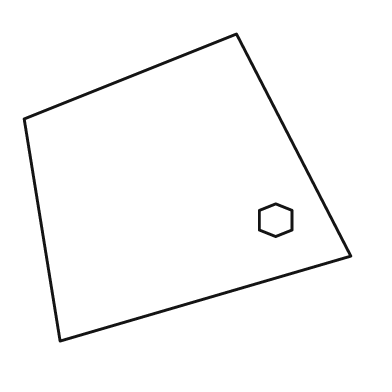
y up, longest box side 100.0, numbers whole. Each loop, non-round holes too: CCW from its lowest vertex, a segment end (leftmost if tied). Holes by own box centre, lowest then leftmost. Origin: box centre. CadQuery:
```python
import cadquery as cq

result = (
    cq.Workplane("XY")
    .moveTo(-39.0, -47.0)
    .lineTo(50.0, -21.0)
    .lineTo(15.0, 47.0)
    .lineTo(-50.0, 21.0)
    .close()
    .moveTo(27.0, -15.0)
    .lineTo(32.0, -13.0)
    .lineTo(32.0, -7.0)
    .lineTo(27.0, -5.0)
    .lineTo(22.0, -7.0)
    .lineTo(22.0, -13.0)
    .close()
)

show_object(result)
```